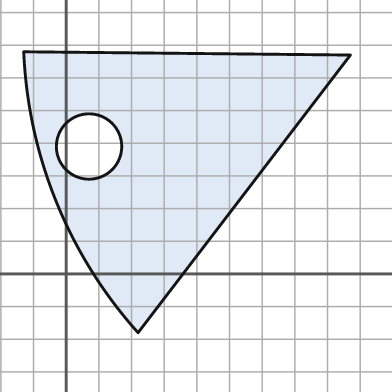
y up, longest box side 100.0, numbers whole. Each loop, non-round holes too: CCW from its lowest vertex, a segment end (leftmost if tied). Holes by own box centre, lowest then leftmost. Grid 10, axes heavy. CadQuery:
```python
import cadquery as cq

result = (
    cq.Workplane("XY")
    .moveTo(22.0, -18.0)
    .lineTo(87.0, 67.0)
    .lineTo(-13.0, 68.0)
    .threePointArc((-3.0, 22.0), (22.0, -18.0))
    .close()
    .moveTo(7.0, 39.0)
    .circle(10.0)
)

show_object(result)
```